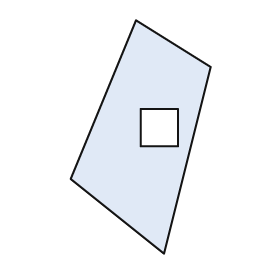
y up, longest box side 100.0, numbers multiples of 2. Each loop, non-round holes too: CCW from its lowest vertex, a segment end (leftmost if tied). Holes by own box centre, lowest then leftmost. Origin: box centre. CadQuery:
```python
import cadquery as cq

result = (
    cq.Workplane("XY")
    .moveTo(10.0, -50.0)
    .lineTo(30.0, 30.0)
    .lineTo(-2.0, 50.0)
    .lineTo(-30.0, -18.0)
    .close()
    .moveTo(0.0, -4.0)
    .lineTo(16.0, -4.0)
    .lineTo(16.0, 12.0)
    .lineTo(0.0, 12.0)
    .close()
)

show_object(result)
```